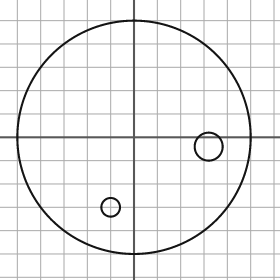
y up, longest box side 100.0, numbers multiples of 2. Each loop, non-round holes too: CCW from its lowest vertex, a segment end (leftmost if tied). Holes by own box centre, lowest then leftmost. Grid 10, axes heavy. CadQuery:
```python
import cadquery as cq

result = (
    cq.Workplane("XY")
    .moveTo(0.0, 0.0)
    .circle(50.0)
    .moveTo(-10.0, -30.0)
    .circle(4.0)
    .moveTo(32.0, -4.0)
    .circle(6.0)
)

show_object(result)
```